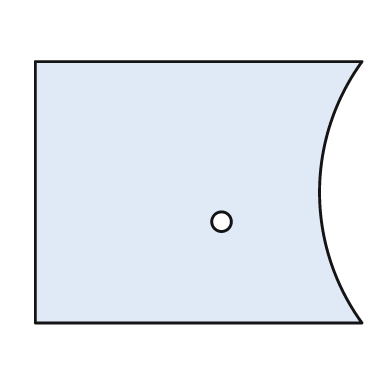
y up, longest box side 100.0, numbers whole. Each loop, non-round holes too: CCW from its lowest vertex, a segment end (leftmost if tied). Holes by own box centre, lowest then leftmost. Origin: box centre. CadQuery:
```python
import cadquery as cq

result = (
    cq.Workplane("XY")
    .moveTo(-50.0, -40.0)
    .lineTo(50.0, -40.0)
    .threePointArc((37.0, 0.0), (50.0, 40.0))
    .lineTo(-50.0, 40.0)
    .close()
    .moveTo(7.0, -9.0)
    .circle(3.0)
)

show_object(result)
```